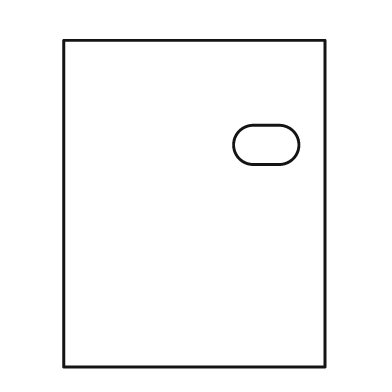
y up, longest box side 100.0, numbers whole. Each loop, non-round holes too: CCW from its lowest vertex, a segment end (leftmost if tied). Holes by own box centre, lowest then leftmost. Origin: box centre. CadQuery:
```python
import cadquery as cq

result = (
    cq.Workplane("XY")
    .moveTo(-40.0, -50.0)
    .lineTo(40.0, -50.0)
    .lineTo(40.0, 50.0)
    .lineTo(-40.0, 50.0)
    .close()
    .moveTo(18.0, 12.0)
    .lineTo(26.0, 12.0)
    .threePointArc((32.0, 18.0), (26.0, 24.0))
    .lineTo(18.0, 24.0)
    .threePointArc((12.0, 18.0), (18.0, 12.0))
    .close()
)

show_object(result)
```